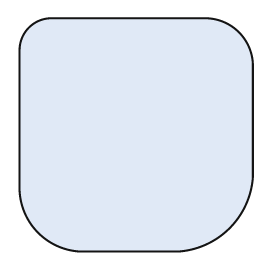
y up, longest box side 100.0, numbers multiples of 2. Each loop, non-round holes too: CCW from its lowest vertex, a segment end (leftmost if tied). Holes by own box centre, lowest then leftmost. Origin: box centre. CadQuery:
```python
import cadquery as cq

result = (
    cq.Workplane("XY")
    .moveTo(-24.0, -50.0)
    .lineTo(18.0, -50.0)
    .threePointArc((40.0, -40.0), (50.0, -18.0))
    .lineTo(50.0, 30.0)
    .threePointArc((44.0, 44.0), (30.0, 50.0))
    .lineTo(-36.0, 50.0)
    .threePointArc((-46.0, 46.0), (-50.0, 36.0))
    .lineTo(-50.0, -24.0)
    .threePointArc((-42.0, -42.0), (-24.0, -50.0))
    .close()
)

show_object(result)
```